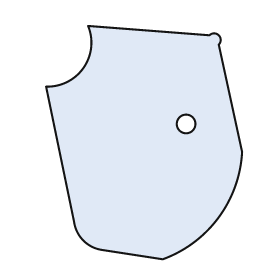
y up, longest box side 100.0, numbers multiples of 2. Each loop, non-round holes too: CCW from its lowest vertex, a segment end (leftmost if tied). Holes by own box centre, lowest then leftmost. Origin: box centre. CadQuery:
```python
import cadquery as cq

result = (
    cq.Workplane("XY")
    .moveTo(8.0, -50.0)
    .threePointArc((32.0, -32.0), (42.0, -4.0))
    .lineTo(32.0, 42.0)
    .threePointArc((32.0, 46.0), (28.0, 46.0))
    .lineTo(-24.0, 50.0)
    .threePointArc((-26.0, 32.0), (-42.0, 24.0))
    .lineTo(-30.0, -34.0)
    .threePointArc((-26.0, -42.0), (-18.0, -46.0))
    .close()
    .moveTo(18.0, 8.0)
    .circle(4.0)
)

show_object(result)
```